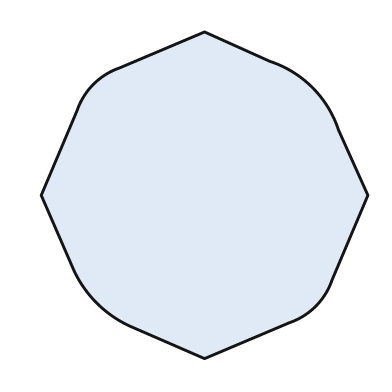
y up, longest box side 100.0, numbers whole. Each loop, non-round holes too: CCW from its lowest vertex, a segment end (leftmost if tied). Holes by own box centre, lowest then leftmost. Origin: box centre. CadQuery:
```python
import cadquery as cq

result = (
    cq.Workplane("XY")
    .moveTo(0.0, -50.0)
    .lineTo(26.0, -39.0)
    .threePointArc((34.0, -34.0), (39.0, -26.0))
    .lineTo(50.0, 0.0)
    .lineTo(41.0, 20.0)
    .threePointArc((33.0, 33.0), (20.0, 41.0))
    .lineTo(0.0, 50.0)
    .lineTo(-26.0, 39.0)
    .threePointArc((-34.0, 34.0), (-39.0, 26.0))
    .lineTo(-50.0, 0.0)
    .lineTo(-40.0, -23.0)
    .threePointArc((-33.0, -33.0), (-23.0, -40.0))
    .close()
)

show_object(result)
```